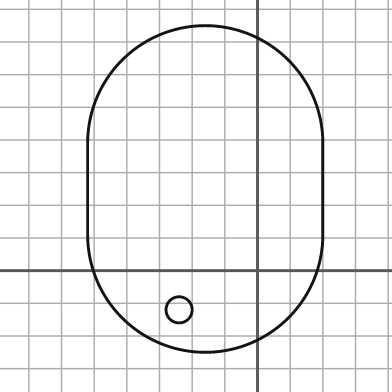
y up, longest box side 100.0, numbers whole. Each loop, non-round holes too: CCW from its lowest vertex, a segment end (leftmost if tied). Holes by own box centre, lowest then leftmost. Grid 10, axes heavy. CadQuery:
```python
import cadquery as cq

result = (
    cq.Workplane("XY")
    .moveTo(-52.0, 11.0)
    .threePointArc((-16.0, -25.0), (20.0, 11.0))
    .lineTo(20.0, 39.0)
    .threePointArc((-16.0, 75.0), (-52.0, 39.0))
    .close()
    .moveTo(-24.0, -12.0)
    .circle(4.0)
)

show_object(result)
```